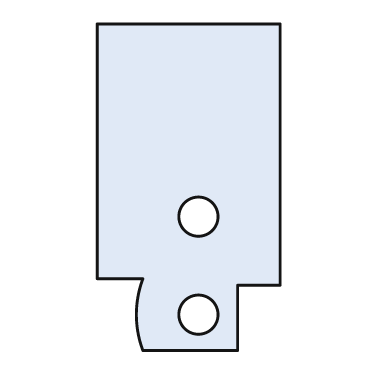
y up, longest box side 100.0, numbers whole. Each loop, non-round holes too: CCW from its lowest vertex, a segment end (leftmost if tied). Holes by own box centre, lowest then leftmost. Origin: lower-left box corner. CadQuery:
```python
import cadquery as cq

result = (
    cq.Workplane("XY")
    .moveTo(14.0, 0.0)
    .lineTo(43.0, 0.0)
    .lineTo(43.0, 20.0)
    .lineTo(56.0, 20.0)
    .lineTo(56.0, 100.0)
    .lineTo(0.0, 100.0)
    .lineTo(0.0, 22.0)
    .lineTo(14.0, 22.0)
    .threePointArc((12.0, 11.0), (14.0, 0.0))
    .close()
    .moveTo(31.0, 11.0)
    .circle(6.0)
    .moveTo(31.0, 41.0)
    .circle(6.0)
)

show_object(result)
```